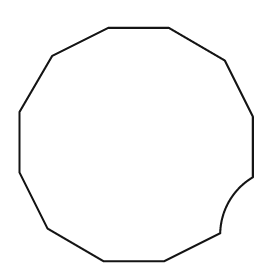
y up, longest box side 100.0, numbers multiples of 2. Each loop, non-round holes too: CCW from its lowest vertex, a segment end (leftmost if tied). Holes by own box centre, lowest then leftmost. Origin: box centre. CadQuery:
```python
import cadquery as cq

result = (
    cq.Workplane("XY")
    .moveTo(-14.0, -50.0)
    .lineTo(12.0, -50.0)
    .lineTo(36.0, -38.0)
    .threePointArc((40.0, -24.0), (50.0, -14.0))
    .lineTo(50.0, 12.0)
    .lineTo(38.0, 36.0)
    .lineTo(14.0, 50.0)
    .lineTo(-12.0, 50.0)
    .lineTo(-36.0, 38.0)
    .lineTo(-50.0, 14.0)
    .lineTo(-50.0, -12.0)
    .lineTo(-38.0, -36.0)
    .close()
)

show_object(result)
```